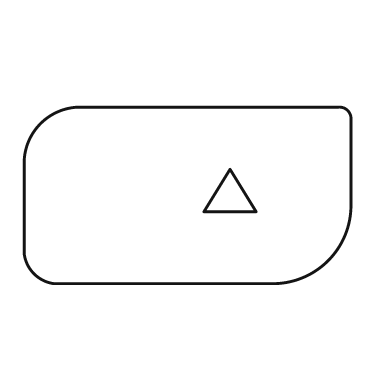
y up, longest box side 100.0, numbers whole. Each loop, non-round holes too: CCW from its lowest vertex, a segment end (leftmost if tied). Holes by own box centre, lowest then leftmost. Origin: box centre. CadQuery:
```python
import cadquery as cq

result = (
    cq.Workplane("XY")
    .moveTo(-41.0, -27.0)
    .lineTo(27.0, -27.0)
    .threePointArc((43.0, -20.0), (50.0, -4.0))
    .lineTo(50.0, 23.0)
    .threePointArc((49.0, 26.0), (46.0, 27.0))
    .lineTo(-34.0, 27.0)
    .threePointArc((-45.0, 22.0), (-50.0, 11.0))
    .lineTo(-50.0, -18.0)
    .threePointArc((-47.0, -24.0), (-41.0, -27.0))
    .close()
    .moveTo(5.0, -5.0)
    .lineTo(21.0, -5.0)
    .lineTo(13.0, 8.0)
    .close()
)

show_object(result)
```